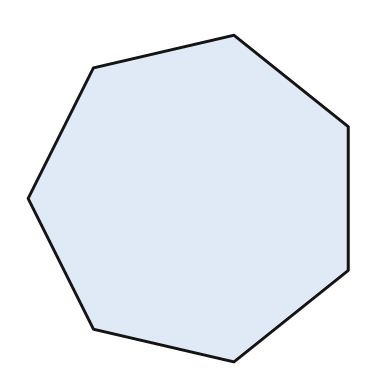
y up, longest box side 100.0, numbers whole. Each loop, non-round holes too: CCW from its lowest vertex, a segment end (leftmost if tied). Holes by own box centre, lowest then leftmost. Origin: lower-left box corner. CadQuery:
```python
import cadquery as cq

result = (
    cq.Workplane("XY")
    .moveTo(63.0, 0.0)
    .lineTo(98.0, 28.0)
    .lineTo(98.0, 72.0)
    .lineTo(63.0, 100.0)
    .lineTo(20.0, 90.0)
    .lineTo(0.0, 50.0)
    .lineTo(20.0, 10.0)
    .close()
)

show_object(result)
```